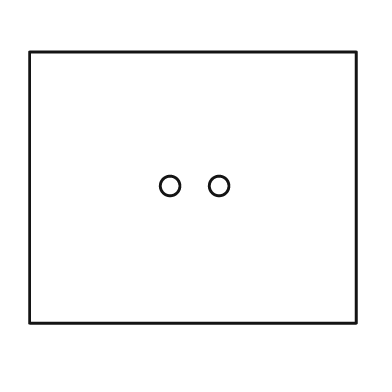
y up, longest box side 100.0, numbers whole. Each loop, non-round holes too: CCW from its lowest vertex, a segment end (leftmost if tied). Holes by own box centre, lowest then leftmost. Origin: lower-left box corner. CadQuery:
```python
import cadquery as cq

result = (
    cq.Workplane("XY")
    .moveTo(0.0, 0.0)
    .lineTo(100.0, 0.0)
    .lineTo(100.0, 83.0)
    .lineTo(0.0, 83.0)
    .close()
    .moveTo(43.0, 42.0)
    .circle(3.0)
    .moveTo(58.0, 42.0)
    .circle(3.0)
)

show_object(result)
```